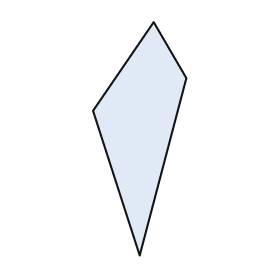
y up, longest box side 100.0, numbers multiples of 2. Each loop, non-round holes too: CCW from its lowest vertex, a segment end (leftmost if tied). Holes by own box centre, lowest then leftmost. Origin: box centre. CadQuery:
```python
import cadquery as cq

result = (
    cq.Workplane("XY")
    .moveTo(0.0, -50.0)
    .lineTo(20.0, 26.0)
    .lineTo(6.0, 50.0)
    .lineTo(-20.0, 12.0)
    .close()
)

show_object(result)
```